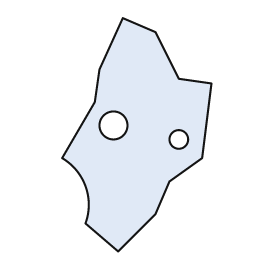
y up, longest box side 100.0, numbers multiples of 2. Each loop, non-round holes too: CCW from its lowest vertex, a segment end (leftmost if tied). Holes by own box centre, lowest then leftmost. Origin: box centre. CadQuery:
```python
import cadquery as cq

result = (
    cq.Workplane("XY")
    .moveTo(-8.0, -50.0)
    .lineTo(8.0, -34.0)
    .lineTo(14.0, -20.0)
    .lineTo(28.0, -10.0)
    .lineTo(32.0, 22.0)
    .lineTo(18.0, 24.0)
    .lineTo(8.0, 44.0)
    .lineTo(-6.0, 50.0)
    .lineTo(-16.0, 28.0)
    .lineTo(-18.0, 14.0)
    .lineTo(-32.0, -10.0)
    .threePointArc((-22.0, -22.0), (-22.0, -38.0))
    .close()
    .moveTo(18.0, -2.0)
    .circle(4.0)
    .moveTo(-10.0, 4.0)
    .circle(6.0)
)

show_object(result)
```